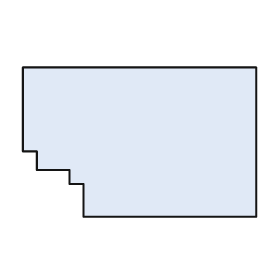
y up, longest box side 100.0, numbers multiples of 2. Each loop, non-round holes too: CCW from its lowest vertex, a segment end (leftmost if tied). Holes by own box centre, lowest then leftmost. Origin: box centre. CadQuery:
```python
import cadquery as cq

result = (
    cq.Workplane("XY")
    .moveTo(-24.0, -32.0)
    .lineTo(50.0, -32.0)
    .lineTo(50.0, 32.0)
    .lineTo(-50.0, 32.0)
    .lineTo(-50.0, -4.0)
    .lineTo(-44.0, -4.0)
    .lineTo(-44.0, -12.0)
    .lineTo(-30.0, -12.0)
    .lineTo(-30.0, -18.0)
    .lineTo(-24.0, -18.0)
    .close()
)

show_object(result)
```